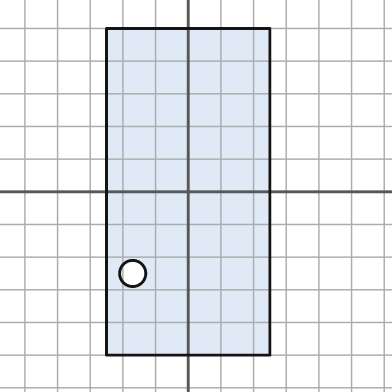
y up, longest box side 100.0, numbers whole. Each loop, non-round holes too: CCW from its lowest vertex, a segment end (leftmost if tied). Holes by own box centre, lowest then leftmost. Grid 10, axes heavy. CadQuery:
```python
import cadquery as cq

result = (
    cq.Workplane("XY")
    .moveTo(-25.0, -50.0)
    .lineTo(25.0, -50.0)
    .lineTo(25.0, 50.0)
    .lineTo(-25.0, 50.0)
    .close()
    .moveTo(-17.0, -25.0)
    .circle(4.0)
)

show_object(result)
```